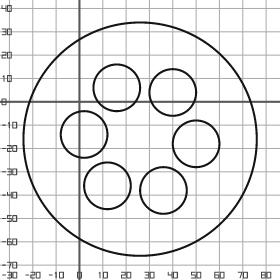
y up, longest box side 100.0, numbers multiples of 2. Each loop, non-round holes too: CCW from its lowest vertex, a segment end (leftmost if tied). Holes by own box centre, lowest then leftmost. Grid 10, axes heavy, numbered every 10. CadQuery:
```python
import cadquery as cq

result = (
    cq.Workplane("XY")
    .moveTo(26.0, -16.0)
    .circle(50.0)
    .moveTo(36.0, -38.0)
    .circle(10.0)
    .moveTo(12.0, -36.0)
    .circle(10.0)
    .moveTo(50.0, -18.0)
    .circle(10.0)
    .moveTo(2.0, -14.0)
    .circle(10.0)
    .moveTo(40.0, 4.0)
    .circle(10.0)
    .moveTo(16.0, 6.0)
    .circle(10.0)
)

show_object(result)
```